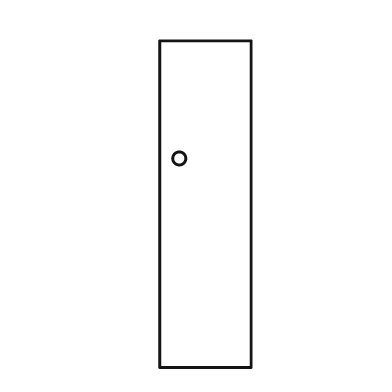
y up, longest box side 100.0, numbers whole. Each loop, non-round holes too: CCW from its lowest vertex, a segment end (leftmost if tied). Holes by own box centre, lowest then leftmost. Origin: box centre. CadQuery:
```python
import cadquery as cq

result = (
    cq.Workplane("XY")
    .moveTo(-14.0, -50.0)
    .lineTo(14.0, -50.0)
    .lineTo(14.0, 50.0)
    .lineTo(-14.0, 50.0)
    .close()
    .moveTo(-8.0, 14.0)
    .circle(2.0)
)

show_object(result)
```